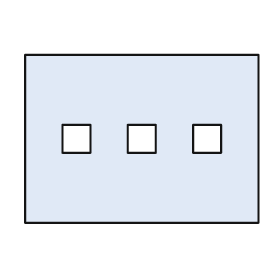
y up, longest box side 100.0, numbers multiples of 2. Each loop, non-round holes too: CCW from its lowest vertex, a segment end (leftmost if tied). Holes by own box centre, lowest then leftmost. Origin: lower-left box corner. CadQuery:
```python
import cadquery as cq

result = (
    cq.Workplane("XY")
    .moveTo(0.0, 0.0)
    .lineTo(100.0, 0.0)
    .lineTo(100.0, 72.0)
    .lineTo(0.0, 72.0)
    .close()
    .moveTo(16.0, 30.0)
    .lineTo(28.0, 30.0)
    .lineTo(28.0, 42.0)
    .lineTo(16.0, 42.0)
    .close()
    .moveTo(44.0, 30.0)
    .lineTo(56.0, 30.0)
    .lineTo(56.0, 42.0)
    .lineTo(44.0, 42.0)
    .close()
    .moveTo(72.0, 30.0)
    .lineTo(84.0, 30.0)
    .lineTo(84.0, 42.0)
    .lineTo(72.0, 42.0)
    .close()
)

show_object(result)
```